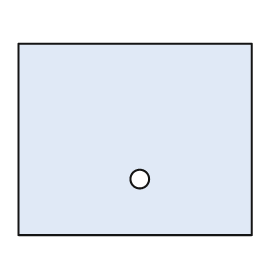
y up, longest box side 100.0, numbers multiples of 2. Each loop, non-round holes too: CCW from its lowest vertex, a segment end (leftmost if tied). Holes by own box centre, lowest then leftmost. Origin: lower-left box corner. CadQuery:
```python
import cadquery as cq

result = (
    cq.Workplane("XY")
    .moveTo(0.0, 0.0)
    .lineTo(100.0, 0.0)
    .lineTo(100.0, 82.0)
    .lineTo(0.0, 82.0)
    .close()
    .moveTo(52.0, 24.0)
    .circle(4.0)
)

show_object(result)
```